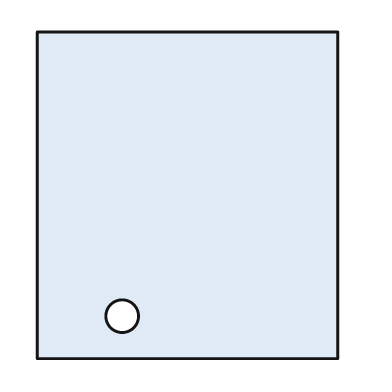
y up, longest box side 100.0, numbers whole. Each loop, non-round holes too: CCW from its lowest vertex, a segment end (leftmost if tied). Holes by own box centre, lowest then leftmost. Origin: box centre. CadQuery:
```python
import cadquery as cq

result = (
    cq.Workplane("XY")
    .moveTo(-46.0, -50.0)
    .lineTo(46.0, -50.0)
    .lineTo(46.0, 50.0)
    .lineTo(-46.0, 50.0)
    .close()
    .moveTo(-20.0, -37.0)
    .circle(5.0)
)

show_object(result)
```